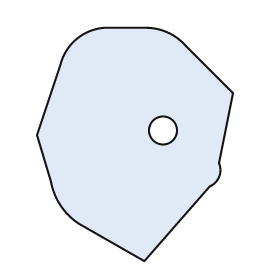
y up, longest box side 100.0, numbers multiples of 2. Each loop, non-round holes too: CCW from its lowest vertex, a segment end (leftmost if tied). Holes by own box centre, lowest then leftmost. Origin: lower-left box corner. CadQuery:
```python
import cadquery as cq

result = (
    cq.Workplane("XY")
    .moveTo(46.0, 0.0)
    .lineTo(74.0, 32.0)
    .threePointArc((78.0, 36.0), (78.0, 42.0))
    .lineTo(84.0, 72.0)
    .lineTo(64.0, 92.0)
    .threePointArc((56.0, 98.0), (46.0, 100.0))
    .lineTo(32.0, 100.0)
    .threePointArc((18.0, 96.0), (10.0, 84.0))
    .lineTo(0.0, 54.0)
    .lineTo(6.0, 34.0)
    .threePointArc((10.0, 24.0), (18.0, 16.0))
    .close()
    .moveTo(54.0, 56.0)
    .circle(6.0)
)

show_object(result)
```